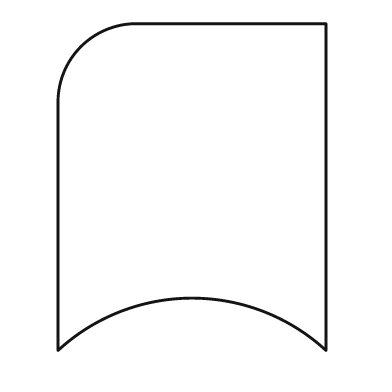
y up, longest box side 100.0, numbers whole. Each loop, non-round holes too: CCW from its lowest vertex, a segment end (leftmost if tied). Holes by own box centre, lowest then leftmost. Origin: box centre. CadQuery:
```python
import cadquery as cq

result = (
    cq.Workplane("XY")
    .moveTo(-41.0, -50.0)
    .threePointArc((0.0, -34.0), (41.0, -50.0))
    .lineTo(41.0, 50.0)
    .lineTo(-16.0, 50.0)
    .threePointArc((-34.0, 43.0), (-41.0, 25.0))
    .close()
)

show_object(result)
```